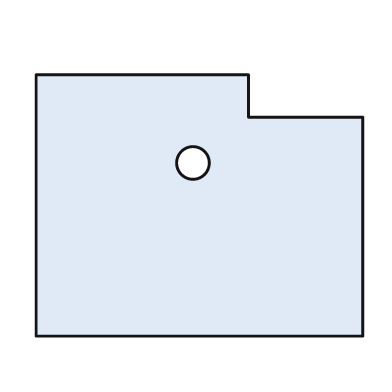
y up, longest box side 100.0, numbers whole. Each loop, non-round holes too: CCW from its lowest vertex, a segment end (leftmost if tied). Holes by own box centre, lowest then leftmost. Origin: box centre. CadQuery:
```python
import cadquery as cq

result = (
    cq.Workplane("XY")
    .moveTo(-50.0, -40.0)
    .lineTo(50.0, -40.0)
    .lineTo(50.0, 27.0)
    .lineTo(15.0, 27.0)
    .lineTo(15.0, 40.0)
    .lineTo(-50.0, 40.0)
    .close()
    .moveTo(-2.0, 13.0)
    .circle(5.0)
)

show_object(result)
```